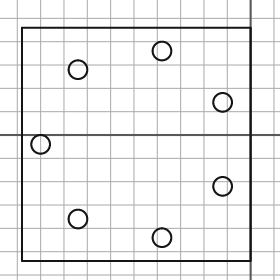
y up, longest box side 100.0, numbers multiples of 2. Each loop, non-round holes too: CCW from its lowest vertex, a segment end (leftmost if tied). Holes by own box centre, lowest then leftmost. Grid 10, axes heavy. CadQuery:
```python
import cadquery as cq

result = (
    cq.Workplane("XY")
    .moveTo(-98.0, -54.0)
    .lineTo(0.0, -54.0)
    .lineTo(0.0, 46.0)
    .lineTo(-98.0, 46.0)
    .close()
    .moveTo(-38.0, -44.0)
    .circle(4.0)
    .moveTo(-74.0, -36.0)
    .circle(4.0)
    .moveTo(-12.0, -22.0)
    .circle(4.0)
    .moveTo(-90.0, -4.0)
    .circle(4.0)
    .moveTo(-12.0, 14.0)
    .circle(4.0)
    .moveTo(-74.0, 28.0)
    .circle(4.0)
    .moveTo(-38.0, 36.0)
    .circle(4.0)
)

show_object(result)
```